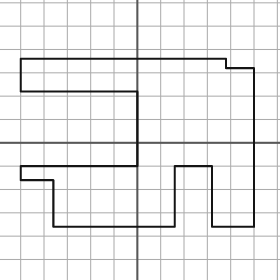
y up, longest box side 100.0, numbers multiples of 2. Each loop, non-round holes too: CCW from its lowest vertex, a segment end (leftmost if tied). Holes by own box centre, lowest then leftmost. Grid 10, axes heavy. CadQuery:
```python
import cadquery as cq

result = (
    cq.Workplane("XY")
    .moveTo(-36.0, -36.0)
    .lineTo(16.0, -36.0)
    .lineTo(16.0, -10.0)
    .lineTo(32.0, -10.0)
    .lineTo(32.0, -36.0)
    .lineTo(50.0, -36.0)
    .lineTo(50.0, 32.0)
    .lineTo(38.0, 32.0)
    .lineTo(38.0, 36.0)
    .lineTo(-50.0, 36.0)
    .lineTo(-50.0, 22.0)
    .lineTo(0.0, 22.0)
    .lineTo(0.0, -10.0)
    .lineTo(-50.0, -10.0)
    .lineTo(-50.0, -16.0)
    .lineTo(-36.0, -16.0)
    .close()
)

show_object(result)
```